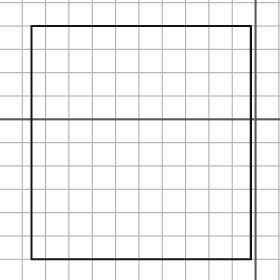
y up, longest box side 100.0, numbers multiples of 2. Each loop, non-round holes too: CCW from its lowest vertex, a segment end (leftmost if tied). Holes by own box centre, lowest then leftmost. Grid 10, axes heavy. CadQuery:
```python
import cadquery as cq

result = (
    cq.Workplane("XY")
    .moveTo(-96.0, -60.0)
    .lineTo(-2.0, -60.0)
    .lineTo(-2.0, 40.0)
    .lineTo(-96.0, 40.0)
    .close()
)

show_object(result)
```